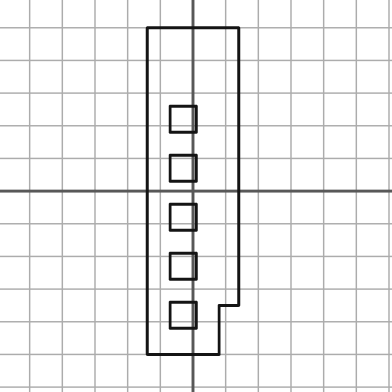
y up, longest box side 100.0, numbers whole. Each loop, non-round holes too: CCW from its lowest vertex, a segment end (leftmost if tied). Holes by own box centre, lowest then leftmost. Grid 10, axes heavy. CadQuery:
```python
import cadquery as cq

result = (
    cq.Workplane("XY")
    .moveTo(-14.0, -50.0)
    .lineTo(8.0, -50.0)
    .lineTo(8.0, -35.0)
    .lineTo(14.0, -35.0)
    .lineTo(14.0, 50.0)
    .lineTo(-14.0, 50.0)
    .close()
    .moveTo(-7.0, -42.0)
    .lineTo(1.0, -42.0)
    .lineTo(1.0, -34.0)
    .lineTo(-7.0, -34.0)
    .close()
    .moveTo(-7.0, -27.0)
    .lineTo(1.0, -27.0)
    .lineTo(1.0, -19.0)
    .lineTo(-7.0, -19.0)
    .close()
    .moveTo(-7.0, -12.0)
    .lineTo(1.0, -12.0)
    .lineTo(1.0, -4.0)
    .lineTo(-7.0, -4.0)
    .close()
    .moveTo(-7.0, 3.0)
    .lineTo(1.0, 3.0)
    .lineTo(1.0, 11.0)
    .lineTo(-7.0, 11.0)
    .close()
    .moveTo(-7.0, 18.0)
    .lineTo(1.0, 18.0)
    .lineTo(1.0, 26.0)
    .lineTo(-7.0, 26.0)
    .close()
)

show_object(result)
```